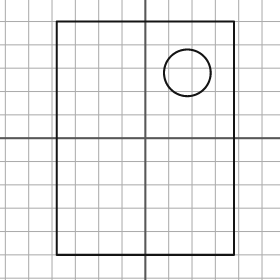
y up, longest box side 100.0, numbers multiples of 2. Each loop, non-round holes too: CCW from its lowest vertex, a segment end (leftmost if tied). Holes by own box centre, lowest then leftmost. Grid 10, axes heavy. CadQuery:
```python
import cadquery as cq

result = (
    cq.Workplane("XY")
    .moveTo(-38.0, -50.0)
    .lineTo(38.0, -50.0)
    .lineTo(38.0, 50.0)
    .lineTo(-38.0, 50.0)
    .close()
    .moveTo(18.0, 28.0)
    .circle(10.0)
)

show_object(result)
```